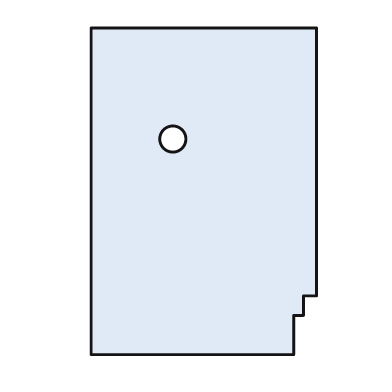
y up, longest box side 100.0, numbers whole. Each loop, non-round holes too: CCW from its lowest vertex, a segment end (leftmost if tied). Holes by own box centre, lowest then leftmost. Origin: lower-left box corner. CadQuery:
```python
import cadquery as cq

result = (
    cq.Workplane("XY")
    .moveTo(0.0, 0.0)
    .lineTo(62.0, 0.0)
    .lineTo(62.0, 12.0)
    .lineTo(65.0, 12.0)
    .lineTo(65.0, 18.0)
    .lineTo(69.0, 18.0)
    .lineTo(69.0, 100.0)
    .lineTo(0.0, 100.0)
    .close()
    .moveTo(25.0, 66.0)
    .circle(4.0)
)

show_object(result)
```